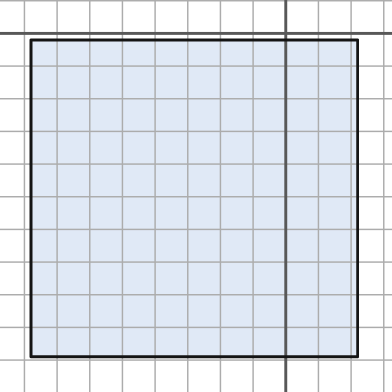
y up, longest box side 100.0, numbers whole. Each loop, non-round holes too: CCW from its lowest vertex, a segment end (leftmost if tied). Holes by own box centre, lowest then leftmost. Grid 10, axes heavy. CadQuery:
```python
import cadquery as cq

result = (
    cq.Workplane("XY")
    .moveTo(-78.0, -99.0)
    .lineTo(22.0, -99.0)
    .lineTo(22.0, -2.0)
    .lineTo(-78.0, -2.0)
    .close()
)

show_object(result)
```